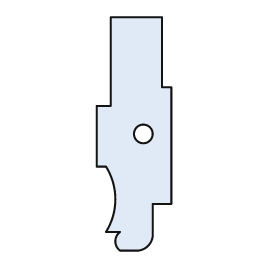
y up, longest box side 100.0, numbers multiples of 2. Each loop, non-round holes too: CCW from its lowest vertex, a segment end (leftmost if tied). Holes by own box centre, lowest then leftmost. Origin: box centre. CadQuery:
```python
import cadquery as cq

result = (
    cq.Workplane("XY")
    .moveTo(-6.0, -50.0)
    .lineTo(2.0, -50.0)
    .threePointArc((6.0, -48.0), (8.0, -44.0))
    .lineTo(8.0, -30.0)
    .lineTo(16.0, -30.0)
    .lineTo(16.0, 20.0)
    .lineTo(12.0, 20.0)
    .lineTo(12.0, 50.0)
    .lineTo(-10.0, 50.0)
    .lineTo(-10.0, 12.0)
    .lineTo(-16.0, 12.0)
    .lineTo(-16.0, -14.0)
    .lineTo(-12.0, -14.0)
    .threePointArc((-8.0, -28.0), (-12.0, -42.0))
    .lineTo(-6.0, -42.0)
    .threePointArc((-8.0, -46.0), (-6.0, -50.0))
    .close()
    .moveTo(4.0, 0.0)
    .circle(4.0)
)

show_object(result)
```